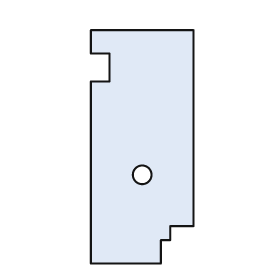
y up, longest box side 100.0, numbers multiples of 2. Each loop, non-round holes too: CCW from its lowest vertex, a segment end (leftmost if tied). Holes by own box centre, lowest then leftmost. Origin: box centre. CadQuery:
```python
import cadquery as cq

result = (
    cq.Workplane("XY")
    .moveTo(-22.0, -50.0)
    .lineTo(8.0, -50.0)
    .lineTo(8.0, -40.0)
    .lineTo(12.0, -40.0)
    .lineTo(12.0, -34.0)
    .lineTo(22.0, -34.0)
    .lineTo(22.0, 50.0)
    .lineTo(-22.0, 50.0)
    .lineTo(-22.0, 40.0)
    .lineTo(-14.0, 40.0)
    .lineTo(-14.0, 28.0)
    .lineTo(-22.0, 28.0)
    .close()
    .moveTo(0.0, -12.0)
    .circle(4.0)
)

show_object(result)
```